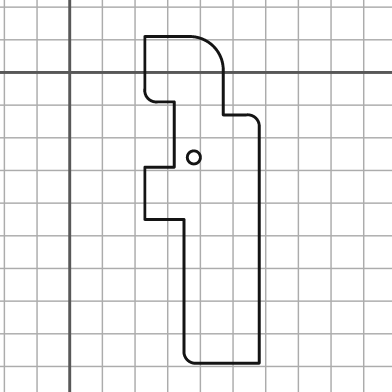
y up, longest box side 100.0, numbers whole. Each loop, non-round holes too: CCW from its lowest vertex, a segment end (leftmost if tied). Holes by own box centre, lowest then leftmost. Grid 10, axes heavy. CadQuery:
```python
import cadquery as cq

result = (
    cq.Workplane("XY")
    .moveTo(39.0, -89.0)
    .lineTo(58.0, -89.0)
    .lineTo(58.0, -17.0)
    .threePointArc((57.0, -14.0), (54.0, -13.0))
    .lineTo(47.0, -13.0)
    .lineTo(47.0, 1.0)
    .threePointArc((44.0, 8.0), (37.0, 11.0))
    .lineTo(23.0, 11.0)
    .lineTo(23.0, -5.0)
    .threePointArc((24.0, -8.0), (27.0, -9.0))
    .lineTo(32.0, -9.0)
    .lineTo(32.0, -29.0)
    .lineTo(23.0, -29.0)
    .lineTo(23.0, -45.0)
    .lineTo(35.0, -45.0)
    .lineTo(35.0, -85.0)
    .threePointArc((36.0, -88.0), (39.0, -89.0))
    .close()
    .moveTo(38.0, -26.0)
    .circle(2.0)
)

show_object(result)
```